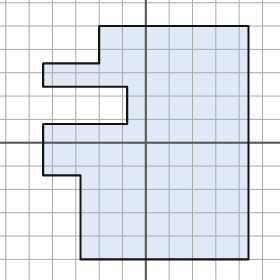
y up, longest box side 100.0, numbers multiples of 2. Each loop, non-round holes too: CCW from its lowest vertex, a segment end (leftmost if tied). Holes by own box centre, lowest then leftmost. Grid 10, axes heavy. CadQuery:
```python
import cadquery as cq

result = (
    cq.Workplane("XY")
    .moveTo(-28.0, -50.0)
    .lineTo(44.0, -50.0)
    .lineTo(44.0, 50.0)
    .lineTo(-20.0, 50.0)
    .lineTo(-20.0, 34.0)
    .lineTo(-44.0, 34.0)
    .lineTo(-44.0, 24.0)
    .lineTo(-8.0, 24.0)
    .lineTo(-8.0, 8.0)
    .lineTo(-44.0, 8.0)
    .lineTo(-44.0, -14.0)
    .lineTo(-28.0, -14.0)
    .close()
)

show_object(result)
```